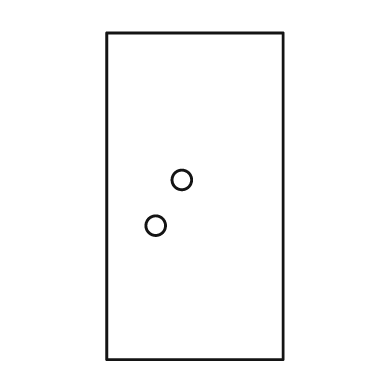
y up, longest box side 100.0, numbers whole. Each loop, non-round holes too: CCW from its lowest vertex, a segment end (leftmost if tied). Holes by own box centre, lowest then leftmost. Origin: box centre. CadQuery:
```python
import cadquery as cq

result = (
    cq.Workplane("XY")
    .moveTo(-27.0, -50.0)
    .lineTo(27.0, -50.0)
    .lineTo(27.0, 50.0)
    .lineTo(-27.0, 50.0)
    .close()
    .moveTo(-12.0, -9.0)
    .circle(3.0)
    .moveTo(-4.0, 5.0)
    .circle(3.0)
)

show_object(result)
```